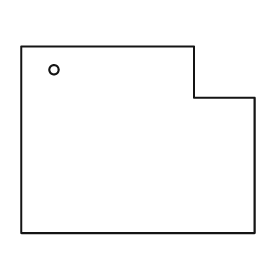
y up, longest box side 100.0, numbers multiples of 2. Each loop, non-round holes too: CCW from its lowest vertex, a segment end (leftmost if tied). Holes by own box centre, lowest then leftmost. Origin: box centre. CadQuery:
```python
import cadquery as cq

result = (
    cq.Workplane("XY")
    .moveTo(-50.0, -40.0)
    .lineTo(50.0, -40.0)
    .lineTo(50.0, 18.0)
    .lineTo(24.0, 18.0)
    .lineTo(24.0, 40.0)
    .lineTo(-50.0, 40.0)
    .close()
    .moveTo(-36.0, 30.0)
    .circle(2.0)
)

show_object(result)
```